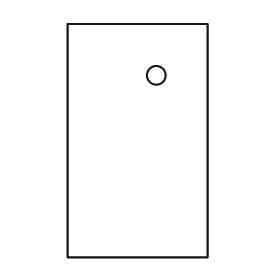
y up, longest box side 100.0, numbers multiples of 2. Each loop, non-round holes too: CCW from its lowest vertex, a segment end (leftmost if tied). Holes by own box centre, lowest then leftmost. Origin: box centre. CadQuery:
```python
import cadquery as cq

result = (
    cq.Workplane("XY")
    .moveTo(-30.0, -50.0)
    .lineTo(30.0, -50.0)
    .lineTo(30.0, 50.0)
    .lineTo(-30.0, 50.0)
    .close()
    .moveTo(8.0, 28.0)
    .circle(4.0)
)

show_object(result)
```